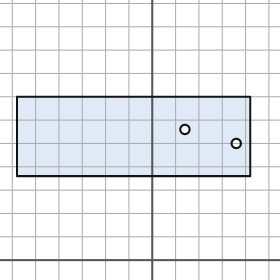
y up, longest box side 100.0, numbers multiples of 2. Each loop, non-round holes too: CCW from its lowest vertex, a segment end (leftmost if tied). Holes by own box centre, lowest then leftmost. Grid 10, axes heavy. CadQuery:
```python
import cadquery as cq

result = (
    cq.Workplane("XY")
    .moveTo(-58.0, 36.0)
    .lineTo(42.0, 36.0)
    .lineTo(42.0, 70.0)
    .lineTo(-58.0, 70.0)
    .close()
    .moveTo(36.0, 50.0)
    .circle(2.0)
    .moveTo(14.0, 56.0)
    .circle(2.0)
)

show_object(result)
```